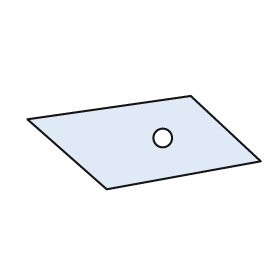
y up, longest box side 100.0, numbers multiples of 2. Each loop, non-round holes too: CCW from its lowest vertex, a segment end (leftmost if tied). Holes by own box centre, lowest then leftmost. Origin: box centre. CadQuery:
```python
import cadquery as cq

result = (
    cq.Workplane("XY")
    .moveTo(-16.0, -20.0)
    .lineTo(50.0, -8.0)
    .lineTo(20.0, 20.0)
    .lineTo(-50.0, 10.0)
    .close()
    .moveTo(8.0, 2.0)
    .circle(4.0)
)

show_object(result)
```